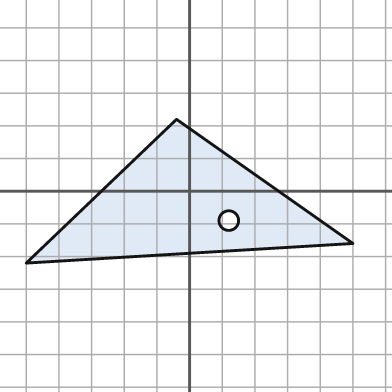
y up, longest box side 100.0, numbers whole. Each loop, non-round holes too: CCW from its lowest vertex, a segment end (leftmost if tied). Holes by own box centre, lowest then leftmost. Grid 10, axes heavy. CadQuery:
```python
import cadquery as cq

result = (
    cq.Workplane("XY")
    .moveTo(-50.0, -22.0)
    .lineTo(50.0, -16.0)
    .lineTo(-4.0, 22.0)
    .close()
    .moveTo(12.0, -9.0)
    .circle(3.0)
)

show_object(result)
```